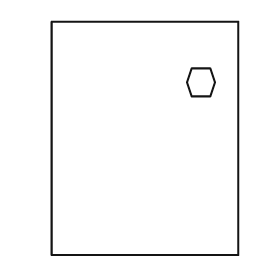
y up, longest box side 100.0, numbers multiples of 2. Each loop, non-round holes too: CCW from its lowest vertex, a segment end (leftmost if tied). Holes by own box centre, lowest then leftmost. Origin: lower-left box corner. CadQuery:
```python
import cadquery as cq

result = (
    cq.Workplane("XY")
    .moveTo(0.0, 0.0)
    .lineTo(80.0, 0.0)
    .lineTo(80.0, 100.0)
    .lineTo(0.0, 100.0)
    .close()
    .moveTo(60.0, 68.0)
    .lineTo(68.0, 68.0)
    .lineTo(70.0, 74.0)
    .lineTo(68.0, 80.0)
    .lineTo(60.0, 80.0)
    .lineTo(58.0, 74.0)
    .close()
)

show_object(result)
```